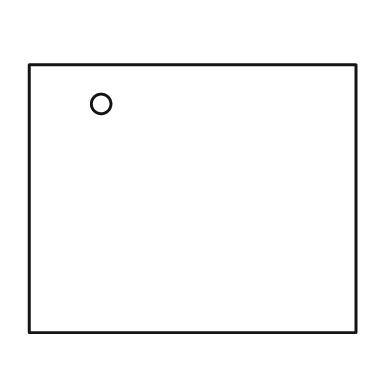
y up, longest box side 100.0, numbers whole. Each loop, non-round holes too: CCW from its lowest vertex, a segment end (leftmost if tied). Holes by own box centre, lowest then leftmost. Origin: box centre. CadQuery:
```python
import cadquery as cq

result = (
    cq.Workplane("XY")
    .moveTo(-50.0, -41.0)
    .lineTo(50.0, -41.0)
    .lineTo(50.0, 41.0)
    .lineTo(-50.0, 41.0)
    .close()
    .moveTo(-28.0, 29.0)
    .circle(3.0)
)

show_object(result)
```